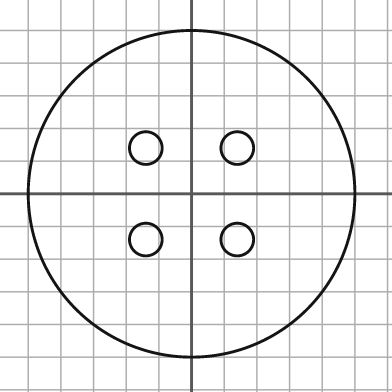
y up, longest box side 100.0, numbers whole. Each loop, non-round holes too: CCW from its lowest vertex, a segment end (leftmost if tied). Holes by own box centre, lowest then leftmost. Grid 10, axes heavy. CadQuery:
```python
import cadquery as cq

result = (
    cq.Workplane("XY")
    .moveTo(0.0, 0.0)
    .circle(50.0)
    .moveTo(-14.0, -14.0)
    .circle(5.0)
    .moveTo(14.0, -14.0)
    .circle(5.0)
    .moveTo(-14.0, 14.0)
    .circle(5.0)
    .moveTo(14.0, 14.0)
    .circle(5.0)
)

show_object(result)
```